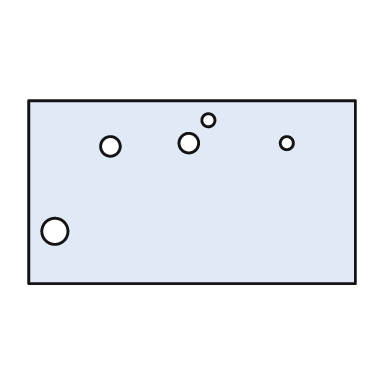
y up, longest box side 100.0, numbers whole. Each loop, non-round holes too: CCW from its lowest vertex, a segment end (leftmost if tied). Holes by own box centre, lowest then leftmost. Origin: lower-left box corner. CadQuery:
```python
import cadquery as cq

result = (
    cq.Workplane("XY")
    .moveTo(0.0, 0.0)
    .lineTo(100.0, 0.0)
    .lineTo(100.0, 56.0)
    .lineTo(0.0, 56.0)
    .close()
    .moveTo(8.0, 16.0)
    .circle(4.0)
    .moveTo(25.0, 42.0)
    .circle(3.0)
    .moveTo(49.0, 43.0)
    .circle(3.0)
    .moveTo(79.0, 43.0)
    .circle(2.0)
    .moveTo(55.0, 50.0)
    .circle(2.0)
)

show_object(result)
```